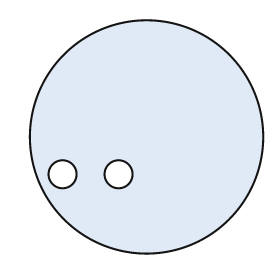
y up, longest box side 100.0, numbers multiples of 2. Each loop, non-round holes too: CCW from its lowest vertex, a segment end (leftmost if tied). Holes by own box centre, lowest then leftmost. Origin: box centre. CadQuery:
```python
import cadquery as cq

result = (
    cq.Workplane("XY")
    .moveTo(0.0, 0.0)
    .circle(50.0)
    .moveTo(-36.0, -16.0)
    .circle(6.0)
    .moveTo(-12.0, -16.0)
    .circle(6.0)
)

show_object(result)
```